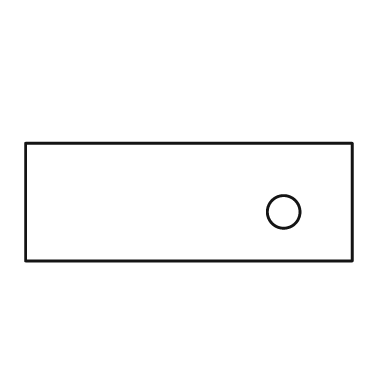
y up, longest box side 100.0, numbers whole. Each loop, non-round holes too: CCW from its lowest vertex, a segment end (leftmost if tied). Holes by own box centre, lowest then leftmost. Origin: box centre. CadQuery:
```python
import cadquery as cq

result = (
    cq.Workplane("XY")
    .moveTo(-50.0, -18.0)
    .lineTo(50.0, -18.0)
    .lineTo(50.0, 18.0)
    .lineTo(-50.0, 18.0)
    .close()
    .moveTo(29.0, -3.0)
    .circle(5.0)
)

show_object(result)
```